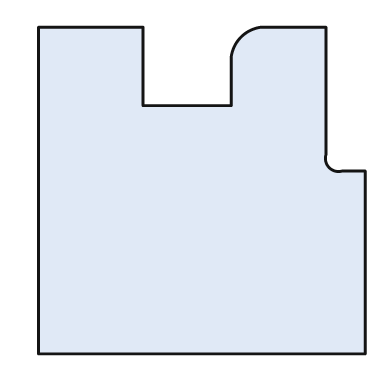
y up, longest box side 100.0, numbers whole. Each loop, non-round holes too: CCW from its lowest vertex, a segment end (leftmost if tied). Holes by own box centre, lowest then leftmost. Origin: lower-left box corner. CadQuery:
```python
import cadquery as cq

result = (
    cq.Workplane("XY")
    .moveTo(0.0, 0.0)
    .lineTo(100.0, 0.0)
    .lineTo(100.0, 56.0)
    .lineTo(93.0, 56.0)
    .threePointArc((89.0, 57.0), (88.0, 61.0))
    .lineTo(88.0, 100.0)
    .lineTo(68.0, 100.0)
    .threePointArc((62.0, 97.0), (59.0, 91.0))
    .lineTo(59.0, 76.0)
    .lineTo(32.0, 76.0)
    .lineTo(32.0, 100.0)
    .lineTo(0.0, 100.0)
    .close()
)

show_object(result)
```